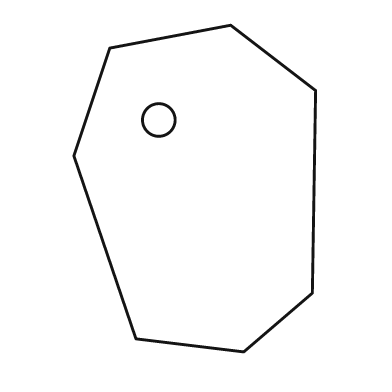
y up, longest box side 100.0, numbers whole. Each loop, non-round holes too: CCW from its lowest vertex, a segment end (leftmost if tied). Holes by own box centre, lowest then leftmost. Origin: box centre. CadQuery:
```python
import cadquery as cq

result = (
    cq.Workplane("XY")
    .moveTo(15.0, -50.0)
    .lineTo(36.0, -32.0)
    .lineTo(37.0, 30.0)
    .lineTo(11.0, 50.0)
    .lineTo(-26.0, 43.0)
    .lineTo(-37.0, 10.0)
    .lineTo(-18.0, -46.0)
    .close()
    .moveTo(-11.0, 21.0)
    .circle(5.0)
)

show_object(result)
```